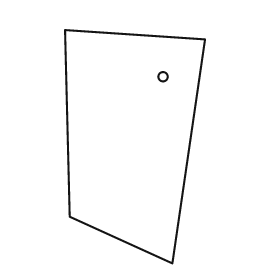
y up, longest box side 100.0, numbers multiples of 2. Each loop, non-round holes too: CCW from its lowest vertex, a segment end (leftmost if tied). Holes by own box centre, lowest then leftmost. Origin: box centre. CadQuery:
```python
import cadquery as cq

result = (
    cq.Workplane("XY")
    .moveTo(16.0, -50.0)
    .lineTo(30.0, 46.0)
    .lineTo(-30.0, 50.0)
    .lineTo(-28.0, -30.0)
    .close()
    .moveTo(12.0, 30.0)
    .circle(2.0)
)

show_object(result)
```